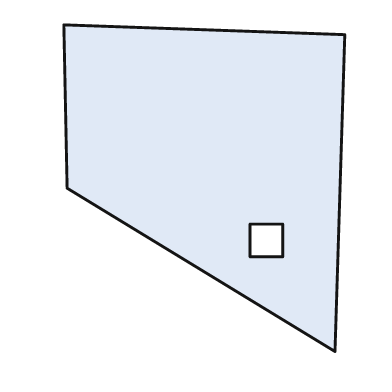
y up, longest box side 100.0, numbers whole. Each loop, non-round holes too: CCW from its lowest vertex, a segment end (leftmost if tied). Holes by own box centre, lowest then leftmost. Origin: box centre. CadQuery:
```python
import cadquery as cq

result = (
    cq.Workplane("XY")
    .moveTo(40.0, -50.0)
    .lineTo(43.0, 47.0)
    .lineTo(-43.0, 50.0)
    .lineTo(-42.0, 0.0)
    .close()
    .moveTo(14.0, -21.0)
    .lineTo(24.0, -21.0)
    .lineTo(24.0, -11.0)
    .lineTo(14.0, -11.0)
    .close()
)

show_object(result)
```